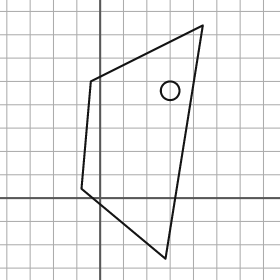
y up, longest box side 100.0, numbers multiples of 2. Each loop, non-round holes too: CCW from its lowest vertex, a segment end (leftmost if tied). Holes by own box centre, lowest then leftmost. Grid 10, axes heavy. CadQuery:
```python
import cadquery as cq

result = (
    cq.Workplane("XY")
    .moveTo(28.0, -26.0)
    .lineTo(44.0, 74.0)
    .lineTo(-4.0, 50.0)
    .lineTo(-8.0, 4.0)
    .close()
    .moveTo(30.0, 46.0)
    .circle(4.0)
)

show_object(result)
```